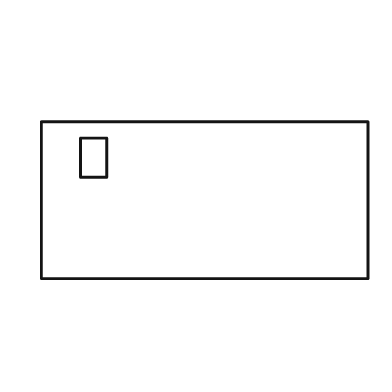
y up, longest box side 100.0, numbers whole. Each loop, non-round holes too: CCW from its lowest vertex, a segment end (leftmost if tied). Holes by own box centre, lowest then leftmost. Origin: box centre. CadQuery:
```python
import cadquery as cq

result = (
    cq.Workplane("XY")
    .moveTo(-50.0, -24.0)
    .lineTo(50.0, -24.0)
    .lineTo(50.0, 24.0)
    .lineTo(-50.0, 24.0)
    .close()
    .moveTo(-38.0, 7.0)
    .lineTo(-30.0, 7.0)
    .lineTo(-30.0, 19.0)
    .lineTo(-38.0, 19.0)
    .close()
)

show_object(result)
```